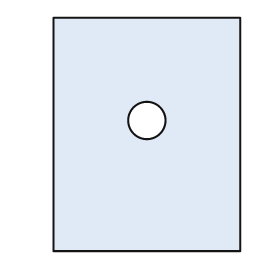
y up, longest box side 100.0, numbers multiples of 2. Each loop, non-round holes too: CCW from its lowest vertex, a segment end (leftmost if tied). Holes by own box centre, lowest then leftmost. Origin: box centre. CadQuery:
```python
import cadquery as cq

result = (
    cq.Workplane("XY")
    .moveTo(-40.0, -50.0)
    .lineTo(40.0, -50.0)
    .lineTo(40.0, 50.0)
    .lineTo(-40.0, 50.0)
    .close()
    .moveTo(0.0, 6.0)
    .circle(8.0)
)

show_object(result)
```